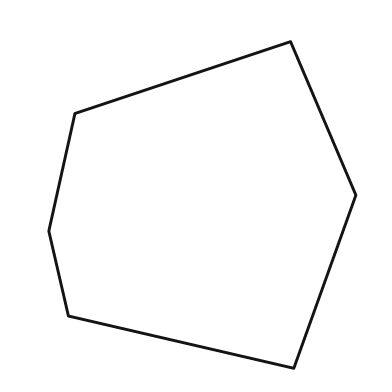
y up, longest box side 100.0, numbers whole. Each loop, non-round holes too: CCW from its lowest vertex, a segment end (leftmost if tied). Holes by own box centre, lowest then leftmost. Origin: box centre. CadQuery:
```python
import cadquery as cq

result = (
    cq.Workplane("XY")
    .moveTo(28.0, -50.0)
    .lineTo(47.0, 3.0)
    .lineTo(27.0, 50.0)
    .lineTo(-39.0, 28.0)
    .lineTo(-47.0, -8.0)
    .lineTo(-41.0, -34.0)
    .close()
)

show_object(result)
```